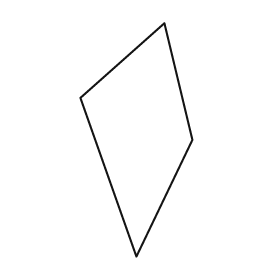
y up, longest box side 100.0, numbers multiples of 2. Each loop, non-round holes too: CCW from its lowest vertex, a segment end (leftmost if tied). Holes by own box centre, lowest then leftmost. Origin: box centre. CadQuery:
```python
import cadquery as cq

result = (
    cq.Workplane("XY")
    .moveTo(0.0, -50.0)
    .lineTo(24.0, 0.0)
    .lineTo(12.0, 50.0)
    .lineTo(-24.0, 18.0)
    .close()
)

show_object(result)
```